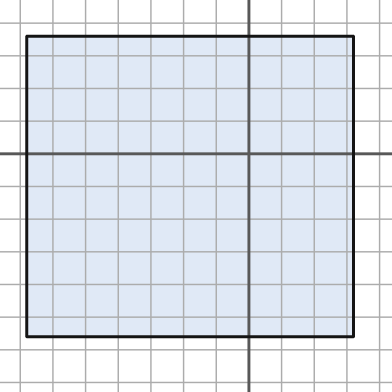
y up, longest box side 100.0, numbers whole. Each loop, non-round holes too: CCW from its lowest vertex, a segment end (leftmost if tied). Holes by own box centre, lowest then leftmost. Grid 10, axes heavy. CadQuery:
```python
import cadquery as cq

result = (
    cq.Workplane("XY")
    .moveTo(-68.0, -56.0)
    .lineTo(32.0, -56.0)
    .lineTo(32.0, 36.0)
    .lineTo(-68.0, 36.0)
    .close()
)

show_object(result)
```